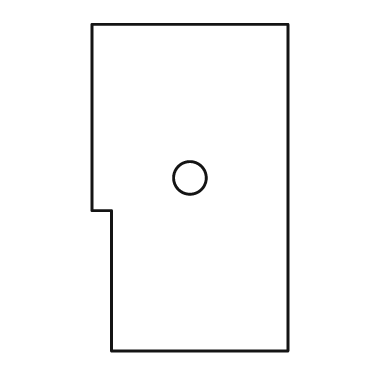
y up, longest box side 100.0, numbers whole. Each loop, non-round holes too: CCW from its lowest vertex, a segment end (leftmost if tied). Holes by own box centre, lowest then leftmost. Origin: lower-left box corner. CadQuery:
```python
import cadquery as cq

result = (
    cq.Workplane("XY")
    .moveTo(6.0, 0.0)
    .lineTo(60.0, 0.0)
    .lineTo(60.0, 100.0)
    .lineTo(0.0, 100.0)
    .lineTo(0.0, 43.0)
    .lineTo(6.0, 43.0)
    .close()
    .moveTo(30.0, 53.0)
    .circle(5.0)
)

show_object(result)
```